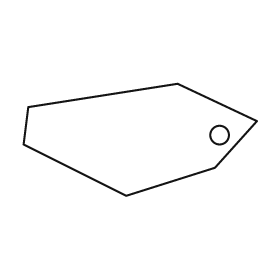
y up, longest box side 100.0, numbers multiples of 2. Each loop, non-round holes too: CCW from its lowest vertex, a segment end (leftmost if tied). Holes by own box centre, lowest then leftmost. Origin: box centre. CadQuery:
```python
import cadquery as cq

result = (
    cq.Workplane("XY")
    .moveTo(-6.0, -24.0)
    .lineTo(32.0, -12.0)
    .lineTo(50.0, 8.0)
    .lineTo(16.0, 24.0)
    .lineTo(-48.0, 14.0)
    .lineTo(-50.0, -2.0)
    .close()
    .moveTo(34.0, 2.0)
    .circle(4.0)
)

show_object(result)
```